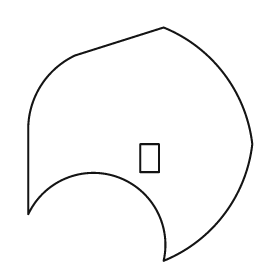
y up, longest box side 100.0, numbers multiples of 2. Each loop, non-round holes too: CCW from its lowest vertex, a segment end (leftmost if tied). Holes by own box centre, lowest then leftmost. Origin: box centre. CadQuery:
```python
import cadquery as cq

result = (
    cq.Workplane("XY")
    .moveTo(10.0, -50.0)
    .threePointArc((36.0, -30.0), (48.0, 0.0))
    .threePointArc((36.0, 30.0), (10.0, 50.0))
    .lineTo(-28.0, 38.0)
    .threePointArc((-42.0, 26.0), (-48.0, 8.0))
    .lineTo(-48.0, -30.0)
    .threePointArc((-10.0, -14.0), (10.0, -50.0))
    .close()
    .moveTo(0.0, -12.0)
    .lineTo(8.0, -12.0)
    .lineTo(8.0, 0.0)
    .lineTo(0.0, 0.0)
    .close()
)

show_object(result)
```